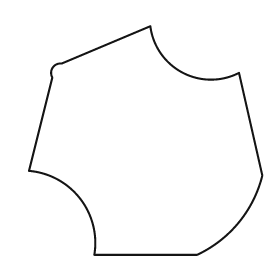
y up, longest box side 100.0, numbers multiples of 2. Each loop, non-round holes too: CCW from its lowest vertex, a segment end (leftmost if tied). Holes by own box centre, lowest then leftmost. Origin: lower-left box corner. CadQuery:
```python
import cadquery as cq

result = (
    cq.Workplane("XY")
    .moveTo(28.0, 0.0)
    .lineTo(72.0, 0.0)
    .threePointArc((90.0, 14.0), (100.0, 34.0))
    .lineTo(90.0, 78.0)
    .threePointArc((66.0, 78.0), (52.0, 98.0))
    .lineTo(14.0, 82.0)
    .threePointArc((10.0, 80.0), (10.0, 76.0))
    .lineTo(0.0, 36.0)
    .threePointArc((22.0, 24.0), (28.0, 0.0))
    .close()
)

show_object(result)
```